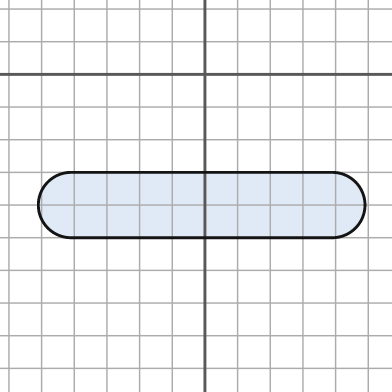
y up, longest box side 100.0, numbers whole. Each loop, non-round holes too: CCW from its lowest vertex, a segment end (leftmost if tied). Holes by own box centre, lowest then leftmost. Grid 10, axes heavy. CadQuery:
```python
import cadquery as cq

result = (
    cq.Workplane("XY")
    .moveTo(-41.0, -50.0)
    .lineTo(39.0, -50.0)
    .threePointArc((49.0, -40.0), (39.0, -30.0))
    .lineTo(-41.0, -30.0)
    .threePointArc((-51.0, -40.0), (-41.0, -50.0))
    .close()
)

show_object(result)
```